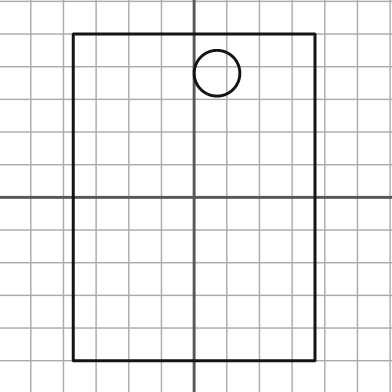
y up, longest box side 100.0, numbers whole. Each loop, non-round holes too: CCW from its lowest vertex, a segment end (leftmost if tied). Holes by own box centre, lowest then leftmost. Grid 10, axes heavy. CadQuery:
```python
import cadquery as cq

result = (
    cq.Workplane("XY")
    .moveTo(-37.0, -50.0)
    .lineTo(37.0, -50.0)
    .lineTo(37.0, 50.0)
    .lineTo(-37.0, 50.0)
    .close()
    .moveTo(7.0, 38.0)
    .circle(7.0)
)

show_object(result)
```